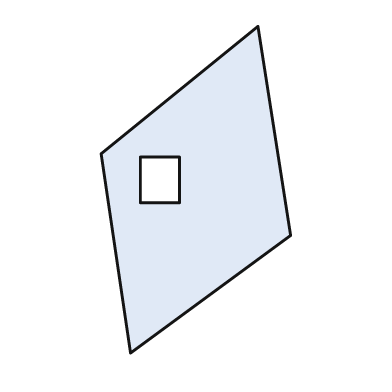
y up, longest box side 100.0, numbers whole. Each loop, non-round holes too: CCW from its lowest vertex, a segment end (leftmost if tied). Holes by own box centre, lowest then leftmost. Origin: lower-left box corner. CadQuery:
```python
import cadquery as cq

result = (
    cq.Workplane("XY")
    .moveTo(9.0, 0.0)
    .lineTo(58.0, 36.0)
    .lineTo(48.0, 100.0)
    .lineTo(0.0, 61.0)
    .close()
    .moveTo(12.0, 46.0)
    .lineTo(24.0, 46.0)
    .lineTo(24.0, 60.0)
    .lineTo(12.0, 60.0)
    .close()
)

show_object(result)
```